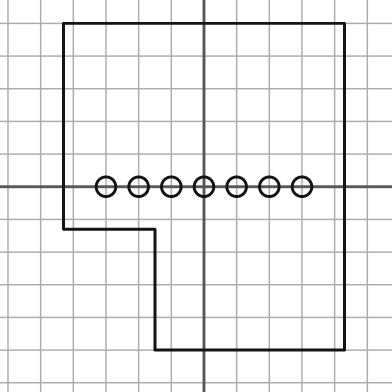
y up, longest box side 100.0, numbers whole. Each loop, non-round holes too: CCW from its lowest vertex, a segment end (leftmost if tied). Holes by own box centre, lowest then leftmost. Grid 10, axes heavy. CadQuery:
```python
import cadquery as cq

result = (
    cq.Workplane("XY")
    .moveTo(-15.0, -50.0)
    .lineTo(43.0, -50.0)
    .lineTo(43.0, 50.0)
    .lineTo(-43.0, 50.0)
    .lineTo(-43.0, -13.0)
    .lineTo(-15.0, -13.0)
    .close()
    .moveTo(-30.0, 0.0)
    .circle(3.0)
    .moveTo(-20.0, 0.0)
    .circle(3.0)
    .moveTo(-10.0, 0.0)
    .circle(3.0)
    .moveTo(0.0, 0.0)
    .circle(3.0)
    .moveTo(10.0, 0.0)
    .circle(3.0)
    .moveTo(20.0, 0.0)
    .circle(3.0)
    .moveTo(30.0, 0.0)
    .circle(3.0)
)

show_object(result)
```